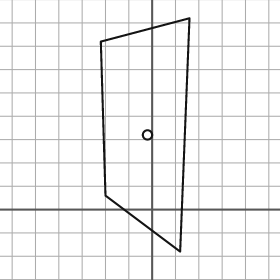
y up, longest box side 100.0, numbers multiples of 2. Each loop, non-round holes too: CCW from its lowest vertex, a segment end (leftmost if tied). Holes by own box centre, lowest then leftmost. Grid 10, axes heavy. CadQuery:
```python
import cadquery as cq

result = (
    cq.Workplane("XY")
    .moveTo(12.0, -18.0)
    .lineTo(16.0, 82.0)
    .lineTo(-22.0, 72.0)
    .lineTo(-20.0, 6.0)
    .close()
    .moveTo(-2.0, 32.0)
    .circle(2.0)
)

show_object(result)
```